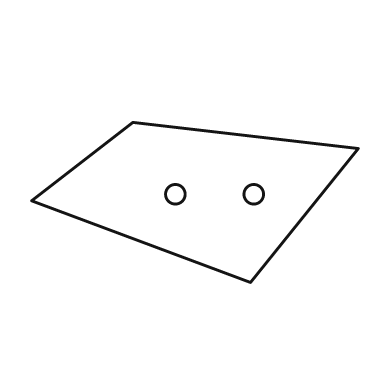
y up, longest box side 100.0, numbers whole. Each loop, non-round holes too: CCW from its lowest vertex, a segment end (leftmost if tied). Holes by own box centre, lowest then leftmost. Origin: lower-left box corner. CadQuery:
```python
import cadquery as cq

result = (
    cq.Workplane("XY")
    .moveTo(67.0, 0.0)
    .lineTo(100.0, 41.0)
    .lineTo(31.0, 49.0)
    .lineTo(0.0, 25.0)
    .close()
    .moveTo(44.0, 27.0)
    .circle(3.0)
    .moveTo(68.0, 27.0)
    .circle(3.0)
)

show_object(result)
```